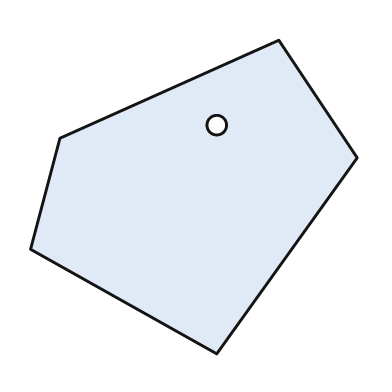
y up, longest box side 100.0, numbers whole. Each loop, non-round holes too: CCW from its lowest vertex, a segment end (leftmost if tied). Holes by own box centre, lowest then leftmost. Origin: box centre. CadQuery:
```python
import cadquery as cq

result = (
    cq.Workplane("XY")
    .moveTo(7.0, -48.0)
    .lineTo(50.0, 12.0)
    .lineTo(26.0, 48.0)
    .lineTo(-41.0, 18.0)
    .lineTo(-50.0, -16.0)
    .close()
    .moveTo(7.0, 22.0)
    .circle(3.0)
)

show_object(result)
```